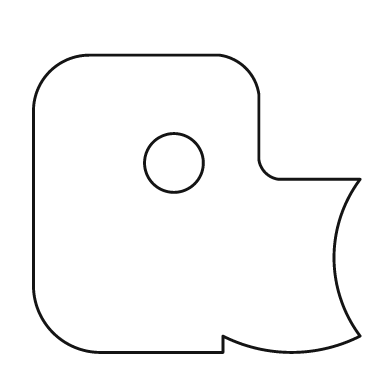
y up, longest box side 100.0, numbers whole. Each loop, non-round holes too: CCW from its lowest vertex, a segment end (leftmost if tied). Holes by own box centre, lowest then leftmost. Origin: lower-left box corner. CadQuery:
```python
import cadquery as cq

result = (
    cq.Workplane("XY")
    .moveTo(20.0, 0.0)
    .lineTo(58.0, 0.0)
    .lineTo(58.0, 5.0)
    .threePointArc((79.0, 0.0), (100.0, 5.0))
    .threePointArc((92.0, 29.0), (100.0, 53.0))
    .lineTo(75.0, 53.0)
    .threePointArc((71.0, 55.0), (69.0, 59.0))
    .lineTo(69.0, 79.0)
    .threePointArc((65.0, 87.0), (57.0, 91.0))
    .lineTo(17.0, 91.0)
    .threePointArc((5.0, 86.0), (0.0, 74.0))
    .lineTo(0.0, 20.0)
    .threePointArc((6.0, 6.0), (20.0, 0.0))
    .close()
    .moveTo(43.0, 58.0)
    .circle(9.0)
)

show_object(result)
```